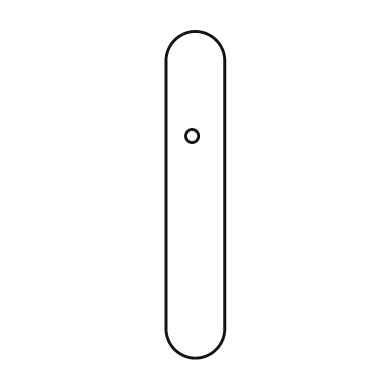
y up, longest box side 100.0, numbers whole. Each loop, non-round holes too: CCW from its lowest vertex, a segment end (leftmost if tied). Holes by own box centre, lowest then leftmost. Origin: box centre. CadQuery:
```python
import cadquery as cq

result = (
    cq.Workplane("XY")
    .moveTo(-9.0, -41.0)
    .threePointArc((0.0, -50.0), (9.0, -41.0))
    .lineTo(9.0, 41.0)
    .threePointArc((0.0, 50.0), (-9.0, 41.0))
    .close()
    .moveTo(-1.0, 18.0)
    .circle(2.0)
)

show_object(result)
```